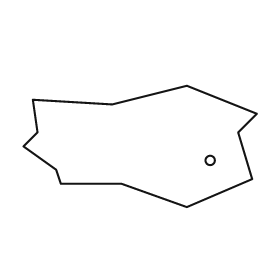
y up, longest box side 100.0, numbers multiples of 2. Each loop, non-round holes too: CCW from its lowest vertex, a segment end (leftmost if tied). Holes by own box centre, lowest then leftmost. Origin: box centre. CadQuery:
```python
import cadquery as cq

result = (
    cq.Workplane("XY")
    .moveTo(20.0, -26.0)
    .lineTo(48.0, -14.0)
    .lineTo(42.0, 6.0)
    .lineTo(50.0, 14.0)
    .lineTo(20.0, 26.0)
    .lineTo(-12.0, 18.0)
    .lineTo(-46.0, 20.0)
    .lineTo(-44.0, 6.0)
    .lineTo(-50.0, 0.0)
    .lineTo(-36.0, -10.0)
    .lineTo(-34.0, -16.0)
    .lineTo(-8.0, -16.0)
    .close()
    .moveTo(30.0, -6.0)
    .circle(2.0)
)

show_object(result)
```